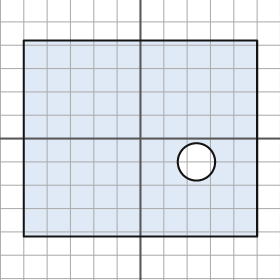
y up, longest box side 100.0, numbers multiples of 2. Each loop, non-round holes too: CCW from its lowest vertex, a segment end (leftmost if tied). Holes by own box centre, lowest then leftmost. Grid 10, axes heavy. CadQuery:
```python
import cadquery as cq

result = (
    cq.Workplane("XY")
    .moveTo(-50.0, -42.0)
    .lineTo(50.0, -42.0)
    .lineTo(50.0, 42.0)
    .lineTo(-50.0, 42.0)
    .close()
    .moveTo(24.0, -10.0)
    .circle(8.0)
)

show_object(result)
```